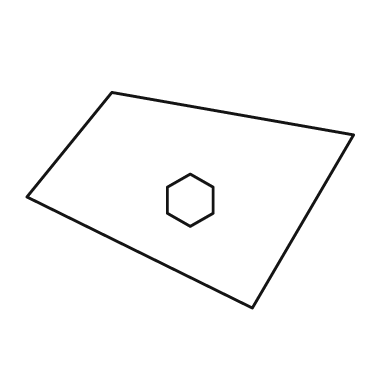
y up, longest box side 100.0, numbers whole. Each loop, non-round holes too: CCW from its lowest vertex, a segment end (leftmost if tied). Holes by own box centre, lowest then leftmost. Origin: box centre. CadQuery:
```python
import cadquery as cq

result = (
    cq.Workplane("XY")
    .moveTo(19.0, -33.0)
    .lineTo(50.0, 20.0)
    .lineTo(-24.0, 33.0)
    .lineTo(-50.0, 1.0)
    .close()
    .moveTo(0.0, -8.0)
    .lineTo(7.0, -4.0)
    .lineTo(7.0, 4.0)
    .lineTo(0.0, 8.0)
    .lineTo(-7.0, 4.0)
    .lineTo(-7.0, -4.0)
    .close()
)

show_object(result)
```